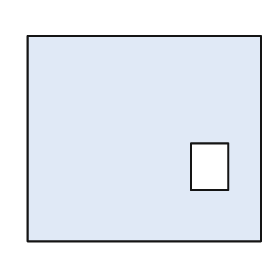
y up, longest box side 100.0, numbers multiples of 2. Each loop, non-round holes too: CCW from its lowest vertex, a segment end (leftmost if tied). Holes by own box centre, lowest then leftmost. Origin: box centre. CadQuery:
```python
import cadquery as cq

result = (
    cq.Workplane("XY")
    .moveTo(-50.0, -44.0)
    .lineTo(50.0, -44.0)
    .lineTo(50.0, 44.0)
    .lineTo(-50.0, 44.0)
    .close()
    .moveTo(20.0, -22.0)
    .lineTo(36.0, -22.0)
    .lineTo(36.0, -2.0)
    .lineTo(20.0, -2.0)
    .close()
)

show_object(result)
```